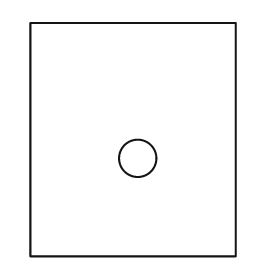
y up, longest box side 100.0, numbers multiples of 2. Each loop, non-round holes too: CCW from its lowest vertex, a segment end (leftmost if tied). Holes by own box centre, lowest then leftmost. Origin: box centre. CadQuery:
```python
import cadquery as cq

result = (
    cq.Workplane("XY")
    .moveTo(-44.0, -50.0)
    .lineTo(44.0, -50.0)
    .lineTo(44.0, 50.0)
    .lineTo(-44.0, 50.0)
    .close()
    .moveTo(2.0, -8.0)
    .circle(8.0)
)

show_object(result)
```